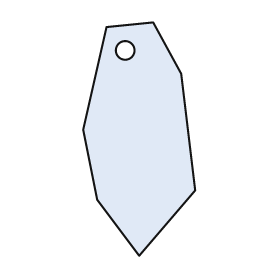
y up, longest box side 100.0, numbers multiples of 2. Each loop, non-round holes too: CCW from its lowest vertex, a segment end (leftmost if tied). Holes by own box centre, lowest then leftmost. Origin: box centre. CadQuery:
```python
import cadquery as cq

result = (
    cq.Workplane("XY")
    .moveTo(0.0, -50.0)
    .lineTo(24.0, -22.0)
    .lineTo(18.0, 28.0)
    .lineTo(6.0, 50.0)
    .lineTo(-14.0, 48.0)
    .lineTo(-24.0, 4.0)
    .lineTo(-18.0, -26.0)
    .close()
    .moveTo(-6.0, 38.0)
    .circle(4.0)
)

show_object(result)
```